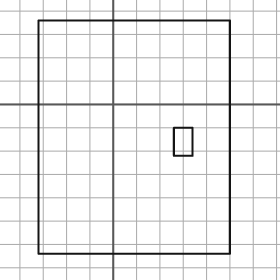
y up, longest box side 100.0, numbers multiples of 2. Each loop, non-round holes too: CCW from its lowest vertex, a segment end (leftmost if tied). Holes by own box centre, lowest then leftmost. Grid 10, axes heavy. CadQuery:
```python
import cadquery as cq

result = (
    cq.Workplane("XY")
    .moveTo(-32.0, -64.0)
    .lineTo(50.0, -64.0)
    .lineTo(50.0, 36.0)
    .lineTo(-32.0, 36.0)
    .close()
    .moveTo(26.0, -22.0)
    .lineTo(34.0, -22.0)
    .lineTo(34.0, -10.0)
    .lineTo(26.0, -10.0)
    .close()
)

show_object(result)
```